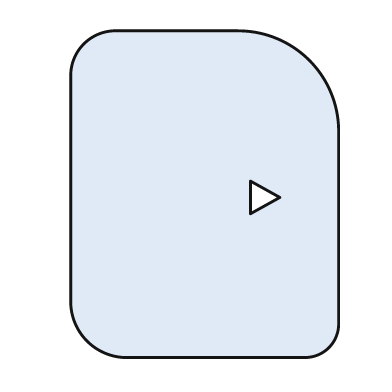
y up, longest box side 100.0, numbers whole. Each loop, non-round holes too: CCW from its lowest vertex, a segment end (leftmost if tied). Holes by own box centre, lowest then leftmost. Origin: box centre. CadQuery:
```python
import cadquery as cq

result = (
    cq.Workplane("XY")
    .moveTo(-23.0, -50.0)
    .lineTo(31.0, -50.0)
    .threePointArc((38.0, -47.0), (41.0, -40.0))
    .lineTo(41.0, 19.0)
    .threePointArc((32.0, 41.0), (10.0, 50.0))
    .lineTo(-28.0, 50.0)
    .threePointArc((-37.0, 46.0), (-41.0, 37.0))
    .lineTo(-41.0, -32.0)
    .threePointArc((-36.0, -45.0), (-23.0, -50.0))
    .close()
    .moveTo(14.0, -6.0)
    .lineTo(23.0, -1.0)
    .lineTo(14.0, 4.0)
    .close()
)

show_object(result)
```